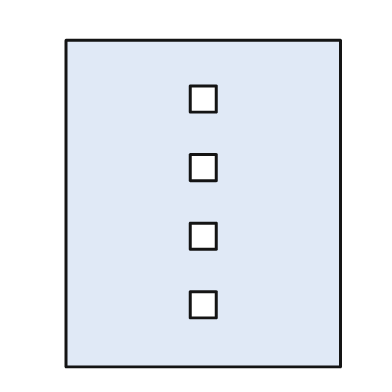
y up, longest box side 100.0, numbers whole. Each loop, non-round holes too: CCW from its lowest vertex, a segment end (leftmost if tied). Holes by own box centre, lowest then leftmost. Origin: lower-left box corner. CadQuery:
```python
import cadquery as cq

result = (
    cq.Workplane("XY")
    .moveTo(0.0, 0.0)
    .lineTo(84.0, 0.0)
    .lineTo(84.0, 100.0)
    .lineTo(0.0, 100.0)
    .close()
    .moveTo(38.0, 15.0)
    .lineTo(46.0, 15.0)
    .lineTo(46.0, 23.0)
    .lineTo(38.0, 23.0)
    .close()
    .moveTo(38.0, 36.0)
    .lineTo(46.0, 36.0)
    .lineTo(46.0, 44.0)
    .lineTo(38.0, 44.0)
    .close()
    .moveTo(38.0, 57.0)
    .lineTo(46.0, 57.0)
    .lineTo(46.0, 65.0)
    .lineTo(38.0, 65.0)
    .close()
    .moveTo(38.0, 78.0)
    .lineTo(46.0, 78.0)
    .lineTo(46.0, 86.0)
    .lineTo(38.0, 86.0)
    .close()
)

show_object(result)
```